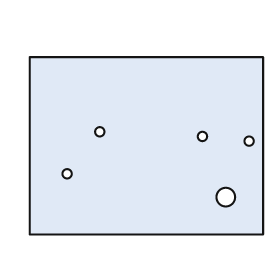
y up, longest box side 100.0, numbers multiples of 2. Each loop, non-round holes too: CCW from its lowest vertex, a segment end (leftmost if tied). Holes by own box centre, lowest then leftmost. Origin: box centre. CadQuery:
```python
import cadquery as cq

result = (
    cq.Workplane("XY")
    .moveTo(-50.0, -38.0)
    .lineTo(50.0, -38.0)
    .lineTo(50.0, 38.0)
    .lineTo(-50.0, 38.0)
    .close()
    .moveTo(34.0, -22.0)
    .circle(4.0)
    .moveTo(-34.0, -12.0)
    .circle(2.0)
    .moveTo(44.0, 2.0)
    .circle(2.0)
    .moveTo(24.0, 4.0)
    .circle(2.0)
    .moveTo(-20.0, 6.0)
    .circle(2.0)
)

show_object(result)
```